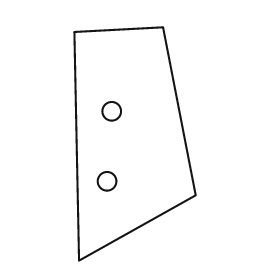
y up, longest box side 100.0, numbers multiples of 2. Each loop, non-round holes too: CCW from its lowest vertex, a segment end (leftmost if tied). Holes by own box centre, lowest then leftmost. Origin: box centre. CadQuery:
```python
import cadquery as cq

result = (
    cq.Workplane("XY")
    .moveTo(-24.0, -50.0)
    .lineTo(26.0, -22.0)
    .lineTo(12.0, 50.0)
    .lineTo(-26.0, 48.0)
    .close()
    .moveTo(-12.0, -16.0)
    .circle(4.0)
    .moveTo(-10.0, 14.0)
    .circle(4.0)
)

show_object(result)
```